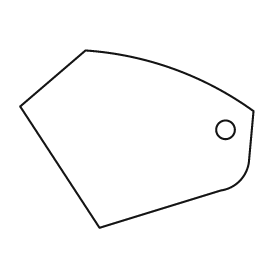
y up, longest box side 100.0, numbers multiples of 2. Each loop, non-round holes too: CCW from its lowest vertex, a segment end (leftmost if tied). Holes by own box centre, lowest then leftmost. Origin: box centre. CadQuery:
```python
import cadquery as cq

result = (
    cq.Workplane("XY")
    .moveTo(-16.0, -38.0)
    .lineTo(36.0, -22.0)
    .threePointArc((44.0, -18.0), (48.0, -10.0))
    .lineTo(50.0, 12.0)
    .threePointArc((16.0, 30.0), (-22.0, 38.0))
    .lineTo(-50.0, 14.0)
    .close()
    .moveTo(38.0, 4.0)
    .circle(4.0)
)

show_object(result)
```